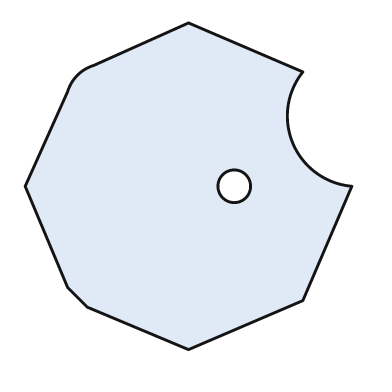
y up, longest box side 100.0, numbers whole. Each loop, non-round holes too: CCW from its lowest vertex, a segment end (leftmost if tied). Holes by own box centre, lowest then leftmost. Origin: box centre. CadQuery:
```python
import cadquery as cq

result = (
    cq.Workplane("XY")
    .moveTo(0.0, -50.0)
    .lineTo(35.0, -35.0)
    .lineTo(50.0, 0.0)
    .threePointArc((32.0, 13.0), (35.0, 35.0))
    .lineTo(0.0, 50.0)
    .lineTo(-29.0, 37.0)
    .threePointArc((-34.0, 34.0), (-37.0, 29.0))
    .lineTo(-50.0, 0.0)
    .lineTo(-37.0, -31.0)
    .lineTo(-31.0, -37.0)
    .close()
    .moveTo(14.0, 0.0)
    .circle(5.0)
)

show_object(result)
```